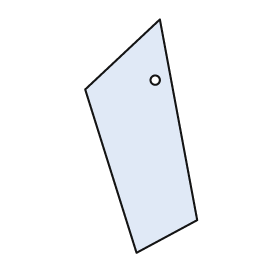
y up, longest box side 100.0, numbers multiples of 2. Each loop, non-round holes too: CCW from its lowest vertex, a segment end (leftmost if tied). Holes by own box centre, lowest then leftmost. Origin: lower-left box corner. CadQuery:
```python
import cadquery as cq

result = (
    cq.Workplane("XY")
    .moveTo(22.0, 0.0)
    .lineTo(48.0, 14.0)
    .lineTo(32.0, 100.0)
    .lineTo(0.0, 70.0)
    .close()
    .moveTo(30.0, 74.0)
    .circle(2.0)
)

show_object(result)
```